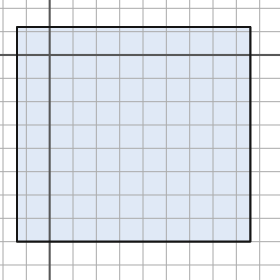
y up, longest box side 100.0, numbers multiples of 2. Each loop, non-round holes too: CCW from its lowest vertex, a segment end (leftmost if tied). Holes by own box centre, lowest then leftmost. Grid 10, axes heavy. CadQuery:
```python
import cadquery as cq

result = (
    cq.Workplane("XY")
    .moveTo(-14.0, -80.0)
    .lineTo(86.0, -80.0)
    .lineTo(86.0, 12.0)
    .lineTo(-14.0, 12.0)
    .close()
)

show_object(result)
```